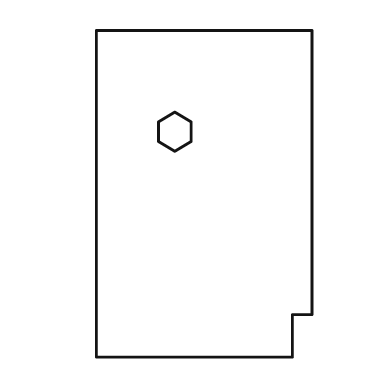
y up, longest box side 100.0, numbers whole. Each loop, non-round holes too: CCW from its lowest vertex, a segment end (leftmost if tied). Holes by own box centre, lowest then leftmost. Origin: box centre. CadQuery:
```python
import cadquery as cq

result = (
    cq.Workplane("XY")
    .moveTo(-33.0, -50.0)
    .lineTo(27.0, -50.0)
    .lineTo(27.0, -37.0)
    .lineTo(33.0, -37.0)
    .lineTo(33.0, 50.0)
    .lineTo(-33.0, 50.0)
    .close()
    .moveTo(-9.0, 13.0)
    .lineTo(-4.0, 16.0)
    .lineTo(-4.0, 22.0)
    .lineTo(-9.0, 25.0)
    .lineTo(-14.0, 22.0)
    .lineTo(-14.0, 16.0)
    .close()
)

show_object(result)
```